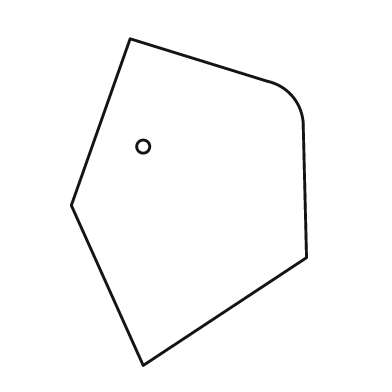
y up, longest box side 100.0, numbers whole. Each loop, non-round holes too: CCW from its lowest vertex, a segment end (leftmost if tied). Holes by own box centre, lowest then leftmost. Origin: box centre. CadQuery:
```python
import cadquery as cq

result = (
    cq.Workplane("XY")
    .moveTo(-14.0, -50.0)
    .lineTo(36.0, -17.0)
    .lineTo(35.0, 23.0)
    .threePointArc((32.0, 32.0), (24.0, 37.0))
    .lineTo(-18.0, 50.0)
    .lineTo(-36.0, -1.0)
    .close()
    .moveTo(-14.0, 17.0)
    .circle(2.0)
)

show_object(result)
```